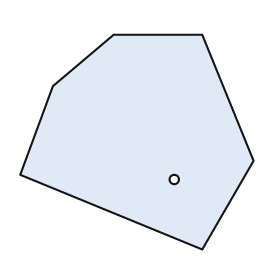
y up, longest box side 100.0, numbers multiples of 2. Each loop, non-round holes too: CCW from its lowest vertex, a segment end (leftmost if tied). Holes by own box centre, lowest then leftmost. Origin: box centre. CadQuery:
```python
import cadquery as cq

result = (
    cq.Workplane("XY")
    .moveTo(28.0, -46.0)
    .lineTo(50.0, -8.0)
    .lineTo(28.0, 46.0)
    .lineTo(-10.0, 46.0)
    .lineTo(-36.0, 24.0)
    .lineTo(-50.0, -14.0)
    .close()
    .moveTo(16.0, -16.0)
    .circle(2.0)
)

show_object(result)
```